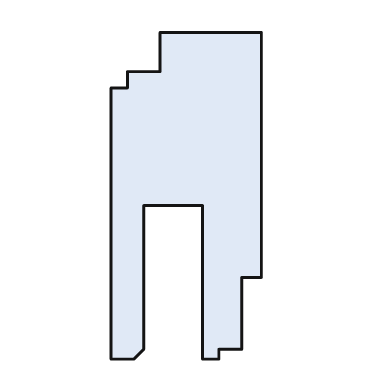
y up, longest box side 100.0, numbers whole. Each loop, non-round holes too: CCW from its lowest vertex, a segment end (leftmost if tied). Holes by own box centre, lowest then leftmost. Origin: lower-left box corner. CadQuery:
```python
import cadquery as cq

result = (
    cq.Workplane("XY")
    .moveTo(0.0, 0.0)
    .lineTo(7.0, 0.0)
    .lineTo(10.0, 3.0)
    .lineTo(10.0, 47.0)
    .lineTo(28.0, 47.0)
    .lineTo(28.0, 0.0)
    .lineTo(33.0, 0.0)
    .lineTo(33.0, 3.0)
    .lineTo(40.0, 3.0)
    .lineTo(40.0, 25.0)
    .lineTo(46.0, 25.0)
    .lineTo(46.0, 100.0)
    .lineTo(15.0, 100.0)
    .lineTo(15.0, 88.0)
    .lineTo(5.0, 88.0)
    .lineTo(5.0, 83.0)
    .lineTo(0.0, 83.0)
    .close()
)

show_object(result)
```